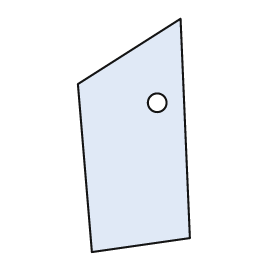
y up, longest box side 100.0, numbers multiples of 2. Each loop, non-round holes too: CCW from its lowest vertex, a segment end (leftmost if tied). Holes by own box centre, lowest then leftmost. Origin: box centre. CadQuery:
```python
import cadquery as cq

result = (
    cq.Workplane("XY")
    .moveTo(-18.0, -50.0)
    .lineTo(24.0, -44.0)
    .lineTo(20.0, 50.0)
    .lineTo(-24.0, 22.0)
    .close()
    .moveTo(10.0, 14.0)
    .circle(4.0)
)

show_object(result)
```